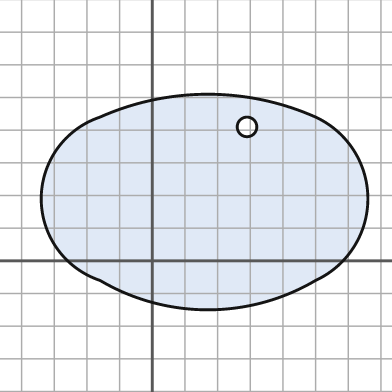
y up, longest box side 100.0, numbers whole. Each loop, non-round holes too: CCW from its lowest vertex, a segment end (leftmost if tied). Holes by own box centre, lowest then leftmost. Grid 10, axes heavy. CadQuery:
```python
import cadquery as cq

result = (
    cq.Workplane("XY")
    .moveTo(-16.0, -6.0)
    .threePointArc((17.0, -15.0), (50.0, -6.0))
    .threePointArc((66.0, 19.0), (50.0, 44.0))
    .threePointArc((17.0, 51.0), (-16.0, 44.0))
    .threePointArc((-34.0, 19.0), (-16.0, -6.0))
    .close()
    .moveTo(29.0, 41.0)
    .circle(3.0)
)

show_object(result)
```